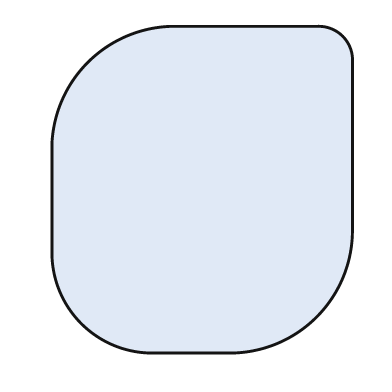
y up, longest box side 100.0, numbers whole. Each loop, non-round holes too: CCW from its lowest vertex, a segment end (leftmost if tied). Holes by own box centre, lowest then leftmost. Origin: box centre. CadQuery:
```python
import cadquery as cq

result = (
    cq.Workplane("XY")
    .moveTo(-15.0, -50.0)
    .lineTo(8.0, -50.0)
    .threePointArc((35.0, -39.0), (46.0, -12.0))
    .lineTo(46.0, 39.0)
    .threePointArc((43.0, 47.0), (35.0, 50.0))
    .lineTo(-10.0, 50.0)
    .threePointArc((-35.0, 39.0), (-46.0, 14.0))
    .lineTo(-46.0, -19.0)
    .threePointArc((-37.0, -41.0), (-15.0, -50.0))
    .close()
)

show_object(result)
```